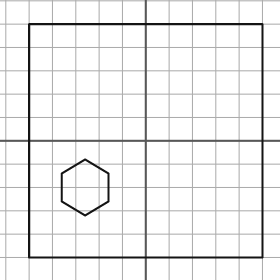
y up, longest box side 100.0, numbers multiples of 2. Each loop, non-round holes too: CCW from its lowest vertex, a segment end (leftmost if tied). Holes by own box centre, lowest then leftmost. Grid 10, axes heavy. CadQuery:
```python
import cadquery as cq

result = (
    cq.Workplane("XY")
    .moveTo(-50.0, -50.0)
    .lineTo(50.0, -50.0)
    .lineTo(50.0, 50.0)
    .lineTo(-50.0, 50.0)
    .close()
    .moveTo(-26.0, -32.0)
    .lineTo(-16.0, -26.0)
    .lineTo(-16.0, -14.0)
    .lineTo(-26.0, -8.0)
    .lineTo(-36.0, -14.0)
    .lineTo(-36.0, -26.0)
    .close()
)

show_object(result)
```